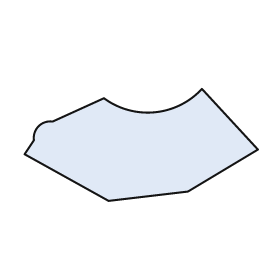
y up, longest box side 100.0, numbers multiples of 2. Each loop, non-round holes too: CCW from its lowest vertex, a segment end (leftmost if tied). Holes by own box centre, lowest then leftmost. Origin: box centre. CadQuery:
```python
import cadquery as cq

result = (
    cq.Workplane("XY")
    .moveTo(-14.0, -24.0)
    .lineTo(20.0, -20.0)
    .lineTo(50.0, -2.0)
    .lineTo(26.0, 24.0)
    .threePointArc((6.0, 14.0), (-16.0, 20.0))
    .lineTo(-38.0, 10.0)
    .threePointArc((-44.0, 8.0), (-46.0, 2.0))
    .lineTo(-50.0, -4.0)
    .close()
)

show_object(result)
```